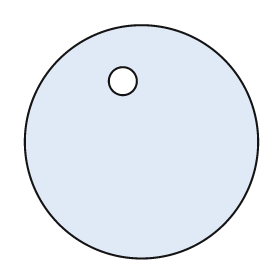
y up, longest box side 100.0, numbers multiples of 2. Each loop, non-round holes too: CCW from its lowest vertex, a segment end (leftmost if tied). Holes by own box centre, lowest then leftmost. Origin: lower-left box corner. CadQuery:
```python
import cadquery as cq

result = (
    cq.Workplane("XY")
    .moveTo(50.0, 50.0)
    .circle(50.0)
    .moveTo(42.0, 76.0)
    .circle(6.0)
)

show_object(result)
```